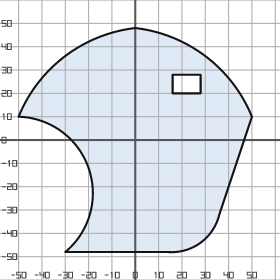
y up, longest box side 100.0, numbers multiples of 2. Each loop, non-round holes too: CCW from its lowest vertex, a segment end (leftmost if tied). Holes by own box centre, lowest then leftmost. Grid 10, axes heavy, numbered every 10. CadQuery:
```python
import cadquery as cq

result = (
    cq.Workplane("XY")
    .moveTo(-30.0, -48.0)
    .lineTo(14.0, -48.0)
    .threePointArc((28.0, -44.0), (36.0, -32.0))
    .lineTo(50.0, 10.0)
    .threePointArc((30.0, 36.0), (0.0, 48.0))
    .threePointArc((-30.0, 36.0), (-50.0, 10.0))
    .threePointArc((-20.0, -12.0), (-30.0, -48.0))
    .close()
    .moveTo(16.0, 20.0)
    .lineTo(28.0, 20.0)
    .lineTo(28.0, 28.0)
    .lineTo(16.0, 28.0)
    .close()
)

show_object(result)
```